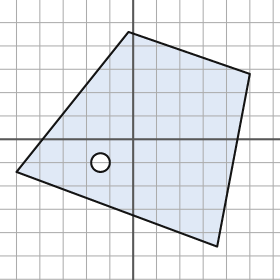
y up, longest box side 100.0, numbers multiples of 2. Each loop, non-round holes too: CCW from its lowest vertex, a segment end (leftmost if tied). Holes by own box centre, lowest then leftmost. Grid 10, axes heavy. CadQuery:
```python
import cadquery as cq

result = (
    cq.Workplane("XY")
    .moveTo(36.0, -46.0)
    .lineTo(50.0, 28.0)
    .lineTo(-2.0, 46.0)
    .lineTo(-50.0, -14.0)
    .close()
    .moveTo(-14.0, -10.0)
    .circle(4.0)
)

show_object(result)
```